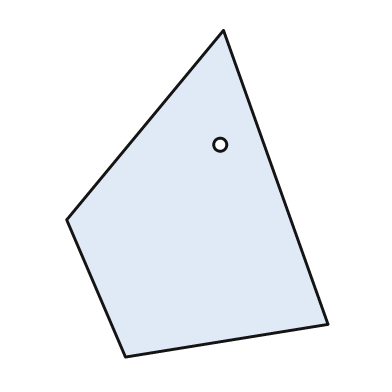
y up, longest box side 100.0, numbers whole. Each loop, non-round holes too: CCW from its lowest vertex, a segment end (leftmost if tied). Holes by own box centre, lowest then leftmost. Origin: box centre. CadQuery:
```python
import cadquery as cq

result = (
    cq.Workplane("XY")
    .moveTo(-22.0, -50.0)
    .lineTo(40.0, -40.0)
    .lineTo(8.0, 50.0)
    .lineTo(-40.0, -8.0)
    .close()
    .moveTo(7.0, 15.0)
    .circle(2.0)
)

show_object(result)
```